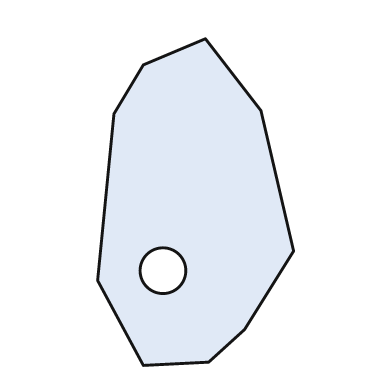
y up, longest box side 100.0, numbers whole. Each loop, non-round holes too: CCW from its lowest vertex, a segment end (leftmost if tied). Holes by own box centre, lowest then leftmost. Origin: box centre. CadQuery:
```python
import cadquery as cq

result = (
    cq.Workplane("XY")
    .moveTo(-16.0, -50.0)
    .lineTo(4.0, -49.0)
    .lineTo(15.0, -39.0)
    .lineTo(30.0, -15.0)
    .lineTo(20.0, 28.0)
    .lineTo(3.0, 50.0)
    .lineTo(-16.0, 42.0)
    .lineTo(-25.0, 27.0)
    .lineTo(-30.0, -24.0)
    .close()
    .moveTo(-10.0, -21.0)
    .circle(7.0)
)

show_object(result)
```